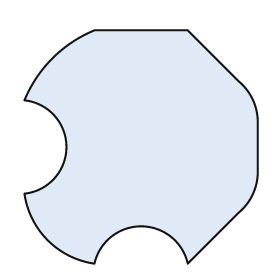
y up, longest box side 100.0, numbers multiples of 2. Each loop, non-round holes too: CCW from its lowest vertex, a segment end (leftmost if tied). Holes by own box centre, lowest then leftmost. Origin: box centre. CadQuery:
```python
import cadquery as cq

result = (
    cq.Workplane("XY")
    .moveTo(-20.0, -50.0)
    .threePointArc((0.0, -34.0), (20.0, -50.0))
    .lineTo(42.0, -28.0)
    .threePointArc((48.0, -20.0), (50.0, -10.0))
    .lineTo(50.0, 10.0)
    .threePointArc((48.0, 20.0), (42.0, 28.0))
    .lineTo(20.0, 50.0)
    .lineTo(-20.0, 50.0)
    .threePointArc((-38.0, 38.0), (-50.0, 20.0))
    .threePointArc((-32.0, 0.0), (-50.0, -20.0))
    .threePointArc((-40.0, -40.0), (-20.0, -50.0))
    .close()
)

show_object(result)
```